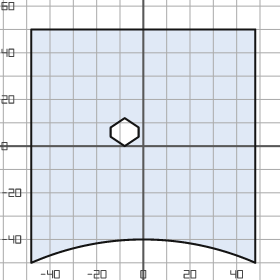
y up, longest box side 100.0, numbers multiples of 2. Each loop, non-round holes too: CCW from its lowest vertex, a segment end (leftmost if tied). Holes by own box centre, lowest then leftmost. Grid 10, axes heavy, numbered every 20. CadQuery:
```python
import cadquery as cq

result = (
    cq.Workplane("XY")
    .moveTo(-48.0, -50.0)
    .threePointArc((0.0, -40.0), (48.0, -50.0))
    .lineTo(48.0, 50.0)
    .lineTo(-48.0, 50.0)
    .close()
    .moveTo(-8.0, 0.0)
    .lineTo(-2.0, 4.0)
    .lineTo(-2.0, 8.0)
    .lineTo(-8.0, 12.0)
    .lineTo(-14.0, 8.0)
    .lineTo(-14.0, 4.0)
    .close()
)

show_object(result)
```